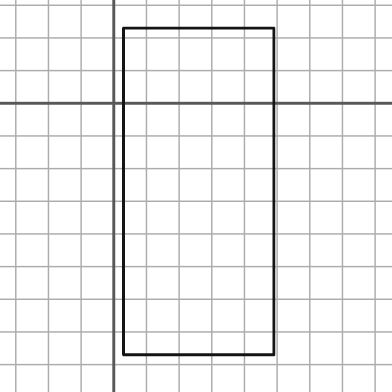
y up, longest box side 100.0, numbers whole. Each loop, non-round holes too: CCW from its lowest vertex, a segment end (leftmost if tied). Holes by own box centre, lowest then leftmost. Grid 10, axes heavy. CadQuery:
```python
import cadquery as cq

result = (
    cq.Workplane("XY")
    .moveTo(3.0, -77.0)
    .lineTo(49.0, -77.0)
    .lineTo(49.0, 23.0)
    .lineTo(3.0, 23.0)
    .close()
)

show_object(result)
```